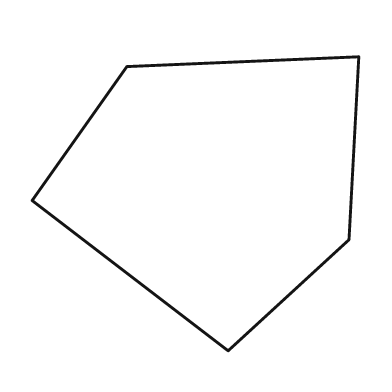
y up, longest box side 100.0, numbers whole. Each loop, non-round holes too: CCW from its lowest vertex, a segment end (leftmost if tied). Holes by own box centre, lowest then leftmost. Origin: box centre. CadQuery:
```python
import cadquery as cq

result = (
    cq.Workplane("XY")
    .moveTo(10.0, -45.0)
    .lineTo(47.0, -11.0)
    .lineTo(50.0, 45.0)
    .lineTo(-21.0, 42.0)
    .lineTo(-50.0, 1.0)
    .close()
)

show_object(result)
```